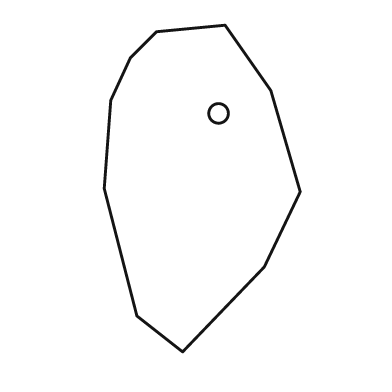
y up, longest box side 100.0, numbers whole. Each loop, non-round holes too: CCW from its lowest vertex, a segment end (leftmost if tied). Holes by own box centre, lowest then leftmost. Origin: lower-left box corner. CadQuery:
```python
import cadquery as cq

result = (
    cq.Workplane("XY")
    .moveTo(24.0, 0.0)
    .lineTo(49.0, 26.0)
    .lineTo(60.0, 49.0)
    .lineTo(51.0, 80.0)
    .lineTo(37.0, 100.0)
    .lineTo(16.0, 98.0)
    .lineTo(8.0, 90.0)
    .lineTo(2.0, 77.0)
    .lineTo(0.0, 50.0)
    .lineTo(10.0, 11.0)
    .close()
    .moveTo(35.0, 73.0)
    .circle(3.0)
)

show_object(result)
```